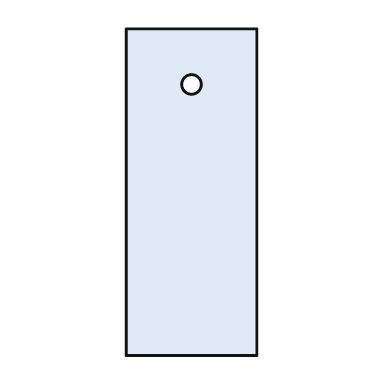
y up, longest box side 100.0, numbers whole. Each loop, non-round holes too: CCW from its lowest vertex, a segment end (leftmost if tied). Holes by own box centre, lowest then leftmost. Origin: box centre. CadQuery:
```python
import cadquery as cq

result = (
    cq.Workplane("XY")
    .moveTo(-20.0, -50.0)
    .lineTo(20.0, -50.0)
    .lineTo(20.0, 50.0)
    .lineTo(-20.0, 50.0)
    .close()
    .moveTo(0.0, 33.0)
    .circle(3.0)
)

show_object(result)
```